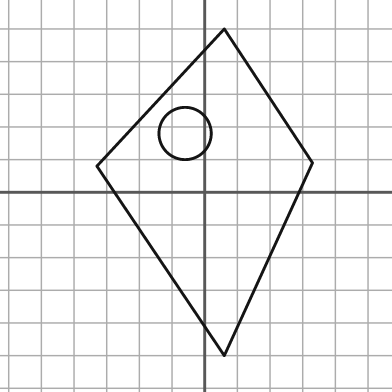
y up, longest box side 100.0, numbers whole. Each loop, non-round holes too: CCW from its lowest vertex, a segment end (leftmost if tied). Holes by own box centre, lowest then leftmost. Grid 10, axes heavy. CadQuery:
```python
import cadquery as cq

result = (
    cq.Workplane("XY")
    .moveTo(6.0, -50.0)
    .lineTo(33.0, 9.0)
    .lineTo(6.0, 50.0)
    .lineTo(-33.0, 8.0)
    .close()
    .moveTo(-6.0, 18.0)
    .circle(8.0)
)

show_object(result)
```